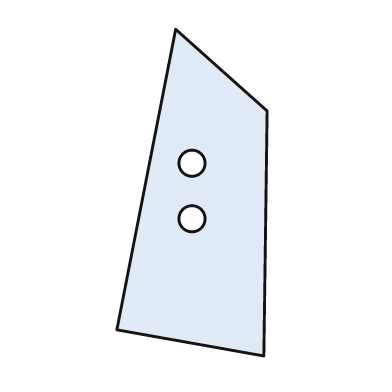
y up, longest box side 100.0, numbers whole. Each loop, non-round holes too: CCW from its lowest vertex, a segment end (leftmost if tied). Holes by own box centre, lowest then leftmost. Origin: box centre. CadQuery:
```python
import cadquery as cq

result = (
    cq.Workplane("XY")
    .moveTo(22.0, -50.0)
    .lineTo(23.0, 25.0)
    .lineTo(-5.0, 50.0)
    .lineTo(-23.0, -42.0)
    .close()
    .moveTo(0.0, -8.0)
    .circle(4.0)
    .moveTo(0.0, 9.0)
    .circle(4.0)
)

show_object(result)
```